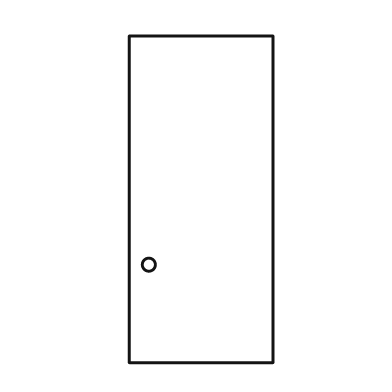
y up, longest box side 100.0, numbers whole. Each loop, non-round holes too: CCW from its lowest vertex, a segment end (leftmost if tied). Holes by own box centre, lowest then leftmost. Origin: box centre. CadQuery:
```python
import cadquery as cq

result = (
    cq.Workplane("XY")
    .moveTo(-22.0, -50.0)
    .lineTo(22.0, -50.0)
    .lineTo(22.0, 50.0)
    .lineTo(-22.0, 50.0)
    .close()
    .moveTo(-16.0, -20.0)
    .circle(2.0)
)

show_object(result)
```